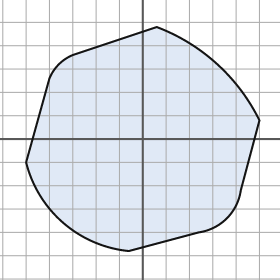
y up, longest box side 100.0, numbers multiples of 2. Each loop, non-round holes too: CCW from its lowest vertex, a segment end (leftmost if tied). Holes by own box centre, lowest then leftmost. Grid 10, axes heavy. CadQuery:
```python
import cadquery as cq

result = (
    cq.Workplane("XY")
    .moveTo(-6.0, -48.0)
    .lineTo(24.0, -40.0)
    .threePointArc((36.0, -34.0), (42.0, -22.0))
    .lineTo(50.0, 8.0)
    .threePointArc((32.0, 32.0), (6.0, 48.0))
    .lineTo(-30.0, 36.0)
    .threePointArc((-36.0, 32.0), (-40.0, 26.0))
    .lineTo(-50.0, -10.0)
    .threePointArc((-34.0, -36.0), (-6.0, -48.0))
    .close()
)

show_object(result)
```